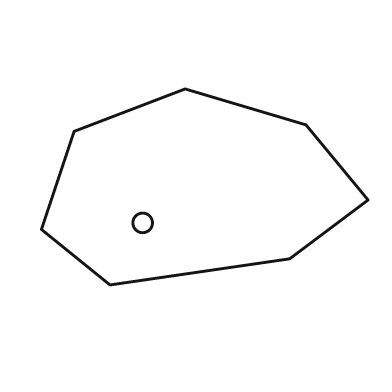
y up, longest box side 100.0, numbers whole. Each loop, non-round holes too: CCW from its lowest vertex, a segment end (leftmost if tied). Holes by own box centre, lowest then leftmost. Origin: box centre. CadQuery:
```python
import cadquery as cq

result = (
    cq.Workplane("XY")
    .moveTo(-29.0, -30.0)
    .lineTo(26.0, -22.0)
    .lineTo(50.0, -4.0)
    .lineTo(31.0, 19.0)
    .lineTo(-6.0, 30.0)
    .lineTo(-40.0, 17.0)
    .lineTo(-50.0, -13.0)
    .close()
    .moveTo(-19.0, -11.0)
    .circle(3.0)
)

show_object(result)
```